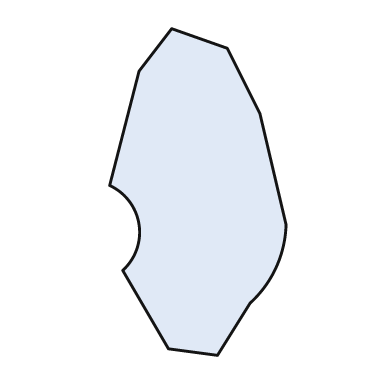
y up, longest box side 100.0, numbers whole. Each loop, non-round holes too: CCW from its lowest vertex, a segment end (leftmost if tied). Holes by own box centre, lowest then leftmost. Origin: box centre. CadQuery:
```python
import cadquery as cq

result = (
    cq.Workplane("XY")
    .moveTo(6.0, -50.0)
    .lineTo(16.0, -34.0)
    .threePointArc((24.0, -23.0), (27.0, -10.0))
    .lineTo(19.0, 24.0)
    .lineTo(9.0, 44.0)
    .lineTo(-8.0, 50.0)
    .lineTo(-18.0, 37.0)
    .lineTo(-27.0, 2.0)
    .threePointArc((-18.0, -10.0), (-23.0, -24.0))
    .lineTo(-9.0, -48.0)
    .close()
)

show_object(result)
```